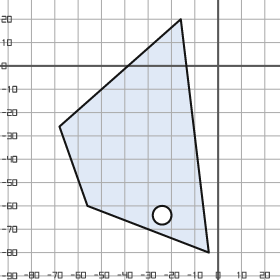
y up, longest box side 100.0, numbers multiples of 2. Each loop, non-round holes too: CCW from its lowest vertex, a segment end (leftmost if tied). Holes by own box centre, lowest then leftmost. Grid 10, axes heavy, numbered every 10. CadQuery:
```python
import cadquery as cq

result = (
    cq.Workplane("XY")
    .moveTo(-4.0, -80.0)
    .lineTo(-16.0, 20.0)
    .lineTo(-68.0, -26.0)
    .lineTo(-56.0, -60.0)
    .close()
    .moveTo(-24.0, -64.0)
    .circle(4.0)
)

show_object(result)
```